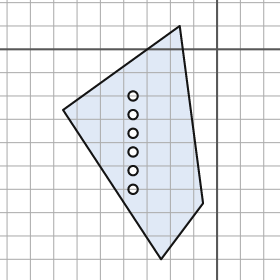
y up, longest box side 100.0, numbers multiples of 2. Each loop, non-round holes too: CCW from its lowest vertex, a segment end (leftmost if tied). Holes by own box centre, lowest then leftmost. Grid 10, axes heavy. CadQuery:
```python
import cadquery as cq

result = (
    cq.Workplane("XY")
    .moveTo(-24.0, -90.0)
    .lineTo(-6.0, -66.0)
    .lineTo(-16.0, 10.0)
    .lineTo(-66.0, -26.0)
    .close()
    .moveTo(-36.0, -60.0)
    .circle(2.0)
    .moveTo(-36.0, -52.0)
    .circle(2.0)
    .moveTo(-36.0, -44.0)
    .circle(2.0)
    .moveTo(-36.0, -36.0)
    .circle(2.0)
    .moveTo(-36.0, -28.0)
    .circle(2.0)
    .moveTo(-36.0, -20.0)
    .circle(2.0)
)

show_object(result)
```